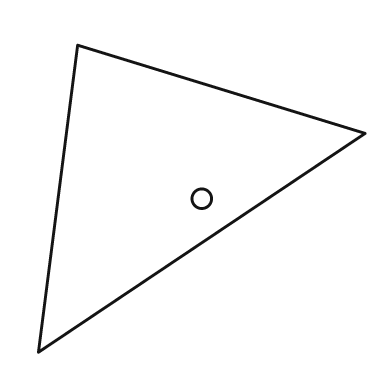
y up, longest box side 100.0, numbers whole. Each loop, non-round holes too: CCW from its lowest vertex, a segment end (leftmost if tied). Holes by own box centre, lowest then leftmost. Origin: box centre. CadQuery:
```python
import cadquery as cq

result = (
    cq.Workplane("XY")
    .moveTo(-50.0, -47.0)
    .lineTo(50.0, 20.0)
    .lineTo(-38.0, 47.0)
    .close()
    .moveTo(0.0, 0.0)
    .circle(3.0)
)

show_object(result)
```